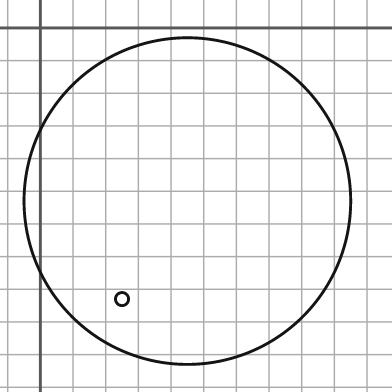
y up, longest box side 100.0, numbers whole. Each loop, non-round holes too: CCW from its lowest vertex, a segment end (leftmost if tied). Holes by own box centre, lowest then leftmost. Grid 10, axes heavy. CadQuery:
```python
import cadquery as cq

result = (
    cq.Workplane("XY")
    .moveTo(45.0, -53.0)
    .circle(50.0)
    .moveTo(25.0, -83.0)
    .circle(2.0)
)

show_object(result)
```